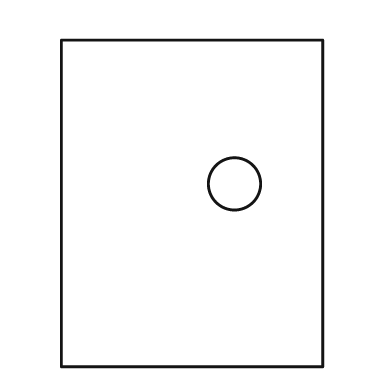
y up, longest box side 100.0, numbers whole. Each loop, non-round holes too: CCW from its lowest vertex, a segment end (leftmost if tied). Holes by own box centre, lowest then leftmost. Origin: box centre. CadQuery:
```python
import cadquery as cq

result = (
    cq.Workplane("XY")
    .moveTo(-40.0, -50.0)
    .lineTo(40.0, -50.0)
    .lineTo(40.0, 50.0)
    .lineTo(-40.0, 50.0)
    .close()
    .moveTo(13.0, 6.0)
    .circle(8.0)
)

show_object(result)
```